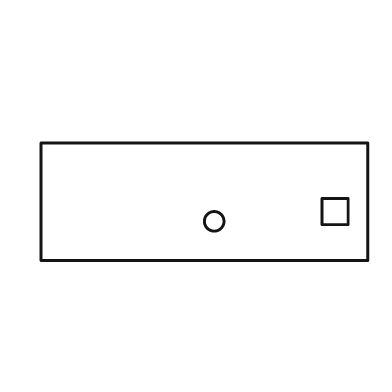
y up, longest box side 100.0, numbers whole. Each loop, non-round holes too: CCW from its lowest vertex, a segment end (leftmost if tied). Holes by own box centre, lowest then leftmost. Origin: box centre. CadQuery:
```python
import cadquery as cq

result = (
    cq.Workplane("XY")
    .moveTo(-50.0, -18.0)
    .lineTo(50.0, -18.0)
    .lineTo(50.0, 18.0)
    .lineTo(-50.0, 18.0)
    .close()
    .moveTo(3.0, -6.0)
    .circle(3.0)
    .moveTo(36.0, -7.0)
    .lineTo(44.0, -7.0)
    .lineTo(44.0, 1.0)
    .lineTo(36.0, 1.0)
    .close()
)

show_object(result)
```